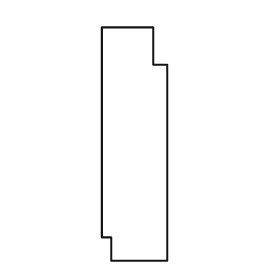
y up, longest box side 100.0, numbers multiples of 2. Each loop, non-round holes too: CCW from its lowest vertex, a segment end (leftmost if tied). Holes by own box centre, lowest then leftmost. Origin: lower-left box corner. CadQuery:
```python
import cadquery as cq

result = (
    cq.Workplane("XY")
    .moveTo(4.0, 0.0)
    .lineTo(28.0, 0.0)
    .lineTo(28.0, 84.0)
    .lineTo(22.0, 84.0)
    .lineTo(22.0, 100.0)
    .lineTo(0.0, 100.0)
    .lineTo(0.0, 10.0)
    .lineTo(4.0, 10.0)
    .close()
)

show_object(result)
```